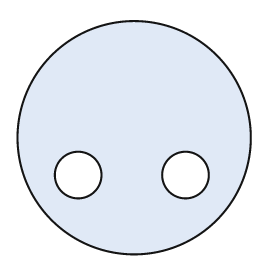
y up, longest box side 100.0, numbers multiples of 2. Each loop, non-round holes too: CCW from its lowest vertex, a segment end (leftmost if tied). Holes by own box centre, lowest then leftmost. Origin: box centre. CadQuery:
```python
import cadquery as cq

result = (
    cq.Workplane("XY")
    .moveTo(0.0, 0.0)
    .circle(50.0)
    .moveTo(-24.0, -16.0)
    .circle(10.0)
    .moveTo(22.0, -16.0)
    .circle(10.0)
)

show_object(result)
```